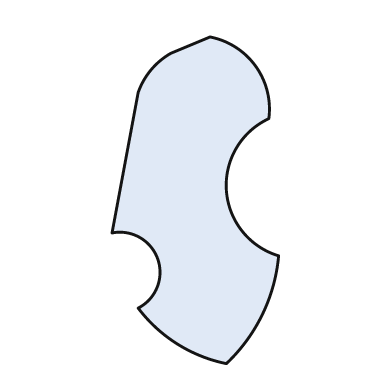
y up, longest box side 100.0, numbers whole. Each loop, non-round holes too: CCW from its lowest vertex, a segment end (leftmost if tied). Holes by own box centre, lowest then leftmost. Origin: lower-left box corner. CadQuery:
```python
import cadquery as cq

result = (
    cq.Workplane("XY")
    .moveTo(35.0, 0.0)
    .threePointArc((46.0, 15.0), (51.0, 33.0))
    .threePointArc((35.0, 53.0), (48.0, 75.0))
    .threePointArc((44.0, 91.0), (30.0, 100.0))
    .lineTo(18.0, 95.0)
    .threePointArc((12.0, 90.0), (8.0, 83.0))
    .lineTo(0.0, 40.0)
    .threePointArc((14.0, 32.0), (8.0, 17.0))
    .threePointArc((20.0, 6.0), (35.0, 0.0))
    .close()
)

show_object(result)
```